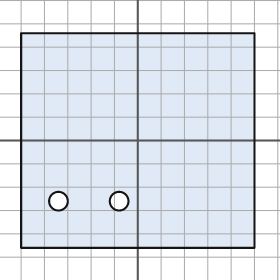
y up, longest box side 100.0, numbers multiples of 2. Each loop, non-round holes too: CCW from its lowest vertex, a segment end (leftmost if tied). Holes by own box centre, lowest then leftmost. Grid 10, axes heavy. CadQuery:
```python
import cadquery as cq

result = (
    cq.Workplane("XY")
    .moveTo(-50.0, -46.0)
    .lineTo(50.0, -46.0)
    .lineTo(50.0, 46.0)
    .lineTo(-50.0, 46.0)
    .close()
    .moveTo(-34.0, -26.0)
    .circle(4.0)
    .moveTo(-8.0, -26.0)
    .circle(4.0)
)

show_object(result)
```